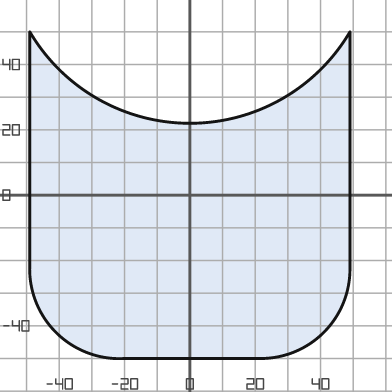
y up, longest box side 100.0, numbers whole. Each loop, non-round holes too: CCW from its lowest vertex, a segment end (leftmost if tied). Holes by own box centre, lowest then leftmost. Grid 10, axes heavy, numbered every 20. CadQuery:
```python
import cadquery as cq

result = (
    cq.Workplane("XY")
    .moveTo(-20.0, -50.0)
    .lineTo(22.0, -50.0)
    .threePointArc((41.0, -42.0), (49.0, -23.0))
    .lineTo(49.0, 50.0)
    .threePointArc((0.0, 22.0), (-49.0, 50.0))
    .lineTo(-49.0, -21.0)
    .threePointArc((-41.0, -42.0), (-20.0, -50.0))
    .close()
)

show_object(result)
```